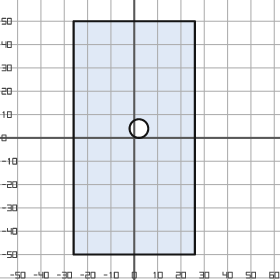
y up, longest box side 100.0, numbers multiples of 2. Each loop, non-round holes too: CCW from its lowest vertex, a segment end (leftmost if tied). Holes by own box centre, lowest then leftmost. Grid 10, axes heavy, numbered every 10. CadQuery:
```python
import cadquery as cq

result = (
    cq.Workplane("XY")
    .moveTo(-26.0, -50.0)
    .lineTo(26.0, -50.0)
    .lineTo(26.0, 50.0)
    .lineTo(-26.0, 50.0)
    .close()
    .moveTo(2.0, 4.0)
    .circle(4.0)
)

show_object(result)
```